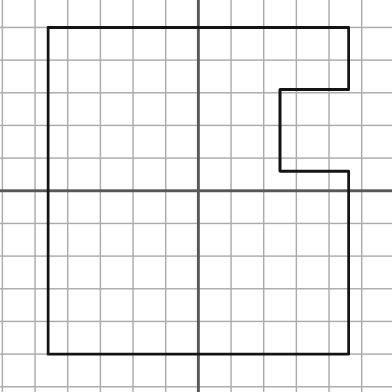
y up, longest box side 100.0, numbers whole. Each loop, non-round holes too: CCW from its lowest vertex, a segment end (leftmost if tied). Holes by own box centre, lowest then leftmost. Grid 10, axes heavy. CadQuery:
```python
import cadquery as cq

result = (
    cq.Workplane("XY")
    .moveTo(-46.0, -50.0)
    .lineTo(46.0, -50.0)
    .lineTo(46.0, 6.0)
    .lineTo(25.0, 6.0)
    .lineTo(25.0, 31.0)
    .lineTo(46.0, 31.0)
    .lineTo(46.0, 50.0)
    .lineTo(-46.0, 50.0)
    .close()
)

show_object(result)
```